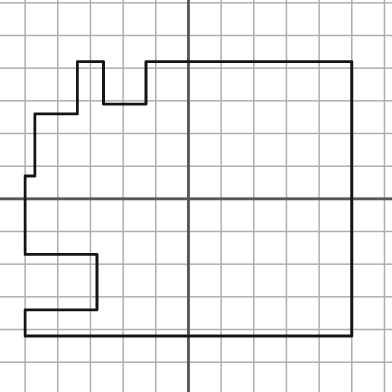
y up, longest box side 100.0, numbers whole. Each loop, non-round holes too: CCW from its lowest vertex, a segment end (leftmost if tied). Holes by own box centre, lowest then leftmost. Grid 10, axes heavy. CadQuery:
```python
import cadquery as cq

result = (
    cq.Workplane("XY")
    .moveTo(-50.0, -42.0)
    .lineTo(50.0, -42.0)
    .lineTo(50.0, 42.0)
    .lineTo(-13.0, 42.0)
    .lineTo(-13.0, 29.0)
    .lineTo(-26.0, 29.0)
    .lineTo(-26.0, 42.0)
    .lineTo(-34.0, 42.0)
    .lineTo(-34.0, 26.0)
    .lineTo(-47.0, 26.0)
    .lineTo(-47.0, 7.0)
    .lineTo(-50.0, 7.0)
    .lineTo(-50.0, -17.0)
    .lineTo(-28.0, -17.0)
    .lineTo(-28.0, -34.0)
    .lineTo(-50.0, -34.0)
    .close()
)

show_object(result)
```